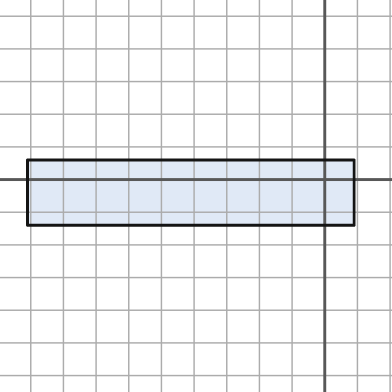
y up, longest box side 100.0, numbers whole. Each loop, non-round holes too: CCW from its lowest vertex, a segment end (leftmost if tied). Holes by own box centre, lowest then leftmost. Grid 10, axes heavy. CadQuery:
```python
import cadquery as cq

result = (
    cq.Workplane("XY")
    .moveTo(-91.0, -14.0)
    .lineTo(9.0, -14.0)
    .lineTo(9.0, 6.0)
    .lineTo(-91.0, 6.0)
    .close()
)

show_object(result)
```